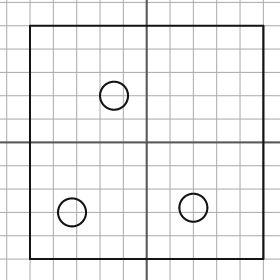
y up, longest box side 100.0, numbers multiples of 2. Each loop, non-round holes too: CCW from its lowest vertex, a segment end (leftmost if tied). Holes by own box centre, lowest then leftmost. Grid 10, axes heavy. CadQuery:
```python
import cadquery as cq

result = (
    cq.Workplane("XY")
    .moveTo(-50.0, -50.0)
    .lineTo(50.0, -50.0)
    .lineTo(50.0, 50.0)
    .lineTo(-50.0, 50.0)
    .close()
    .moveTo(-32.0, -30.0)
    .circle(6.0)
    .moveTo(20.0, -28.0)
    .circle(6.0)
    .moveTo(-14.0, 20.0)
    .circle(6.0)
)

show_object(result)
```